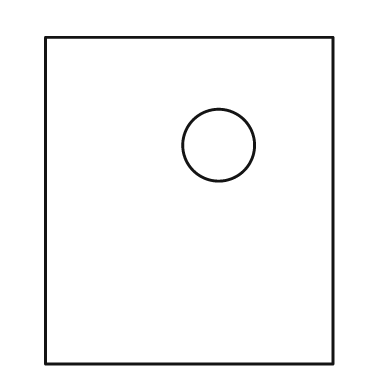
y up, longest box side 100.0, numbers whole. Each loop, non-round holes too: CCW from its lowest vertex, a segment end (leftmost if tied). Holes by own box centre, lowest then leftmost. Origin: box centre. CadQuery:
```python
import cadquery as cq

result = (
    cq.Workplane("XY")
    .moveTo(-44.0, -50.0)
    .lineTo(44.0, -50.0)
    .lineTo(44.0, 50.0)
    .lineTo(-44.0, 50.0)
    .close()
    .moveTo(9.0, 17.0)
    .circle(11.0)
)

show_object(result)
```